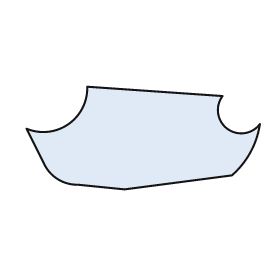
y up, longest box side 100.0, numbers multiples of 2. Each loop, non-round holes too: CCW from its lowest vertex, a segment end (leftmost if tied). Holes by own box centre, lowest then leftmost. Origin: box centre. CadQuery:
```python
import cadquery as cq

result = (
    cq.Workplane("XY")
    .moveTo(-8.0, -22.0)
    .lineTo(38.0, -16.0)
    .threePointArc((46.0, -6.0), (50.0, 6.0))
    .threePointArc((36.0, 4.0), (34.0, 18.0))
    .lineTo(-24.0, 22.0)
    .threePointArc((-32.0, 6.0), (-50.0, 4.0))
    .lineTo(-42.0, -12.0)
    .threePointArc((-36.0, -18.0), (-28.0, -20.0))
    .close()
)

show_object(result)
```